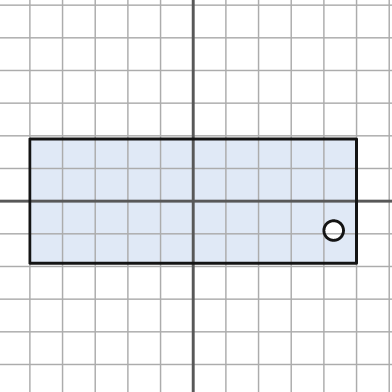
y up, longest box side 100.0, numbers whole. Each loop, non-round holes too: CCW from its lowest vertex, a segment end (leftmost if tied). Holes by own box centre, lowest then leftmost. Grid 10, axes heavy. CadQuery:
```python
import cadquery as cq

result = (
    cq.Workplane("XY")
    .moveTo(-50.0, -19.0)
    .lineTo(50.0, -19.0)
    .lineTo(50.0, 19.0)
    .lineTo(-50.0, 19.0)
    .close()
    .moveTo(43.0, -9.0)
    .circle(3.0)
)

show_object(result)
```